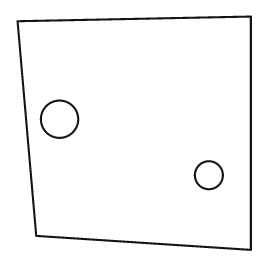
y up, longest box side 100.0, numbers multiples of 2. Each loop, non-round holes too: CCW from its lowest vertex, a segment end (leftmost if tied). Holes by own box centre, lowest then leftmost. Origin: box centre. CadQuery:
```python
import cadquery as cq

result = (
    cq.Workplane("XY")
    .moveTo(50.0, -50.0)
    .lineTo(50.0, 50.0)
    .lineTo(-50.0, 48.0)
    .lineTo(-42.0, -44.0)
    .close()
    .moveTo(32.0, -18.0)
    .circle(6.0)
    .moveTo(-32.0, 6.0)
    .circle(8.0)
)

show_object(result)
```